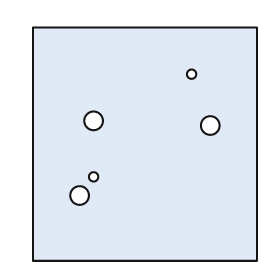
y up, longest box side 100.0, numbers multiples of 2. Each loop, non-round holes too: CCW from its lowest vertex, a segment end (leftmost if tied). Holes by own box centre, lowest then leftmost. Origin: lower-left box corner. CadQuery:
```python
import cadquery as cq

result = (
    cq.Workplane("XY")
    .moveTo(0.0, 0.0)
    .lineTo(96.0, 0.0)
    .lineTo(96.0, 100.0)
    .lineTo(0.0, 100.0)
    .close()
    .moveTo(20.0, 28.0)
    .circle(4.0)
    .moveTo(26.0, 36.0)
    .circle(2.0)
    .moveTo(76.0, 58.0)
    .circle(4.0)
    .moveTo(26.0, 60.0)
    .circle(4.0)
    .moveTo(68.0, 80.0)
    .circle(2.0)
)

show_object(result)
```